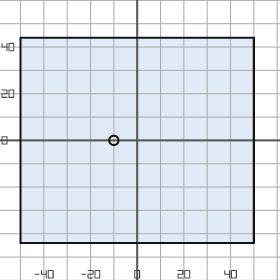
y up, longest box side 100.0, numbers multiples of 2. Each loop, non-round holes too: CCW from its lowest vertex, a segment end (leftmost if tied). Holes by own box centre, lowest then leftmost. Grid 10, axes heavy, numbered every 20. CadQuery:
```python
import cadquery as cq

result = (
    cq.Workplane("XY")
    .moveTo(-50.0, -44.0)
    .lineTo(50.0, -44.0)
    .lineTo(50.0, 44.0)
    .lineTo(-50.0, 44.0)
    .close()
    .moveTo(-10.0, 0.0)
    .circle(2.0)
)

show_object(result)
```